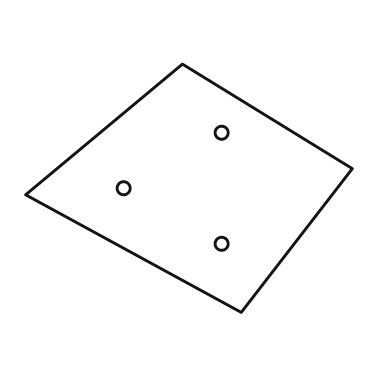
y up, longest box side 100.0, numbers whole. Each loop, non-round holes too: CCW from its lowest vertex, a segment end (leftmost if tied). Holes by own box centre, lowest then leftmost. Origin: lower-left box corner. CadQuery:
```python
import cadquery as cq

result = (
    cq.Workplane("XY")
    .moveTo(66.0, 0.0)
    .lineTo(100.0, 44.0)
    .lineTo(48.0, 76.0)
    .lineTo(0.0, 36.0)
    .close()
    .moveTo(60.0, 21.0)
    .circle(2.0)
    .moveTo(30.0, 38.0)
    .circle(2.0)
    .moveTo(60.0, 55.0)
    .circle(2.0)
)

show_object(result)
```